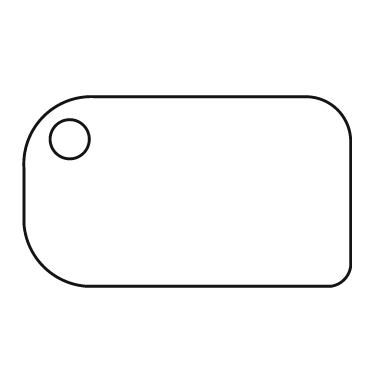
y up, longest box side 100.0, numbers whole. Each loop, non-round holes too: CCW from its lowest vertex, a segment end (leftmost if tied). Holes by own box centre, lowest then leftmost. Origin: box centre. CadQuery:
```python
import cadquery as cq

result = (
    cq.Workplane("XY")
    .moveTo(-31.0, -29.0)
    .lineTo(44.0, -29.0)
    .threePointArc((48.0, -27.0), (50.0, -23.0))
    .lineTo(50.0, 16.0)
    .threePointArc((46.0, 25.0), (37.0, 29.0))
    .lineTo(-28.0, 29.0)
    .threePointArc((-44.0, 23.0), (-50.0, 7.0))
    .lineTo(-50.0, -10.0)
    .threePointArc((-44.0, -23.0), (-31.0, -29.0))
    .close()
    .moveTo(-36.0, 16.0)
    .circle(6.0)
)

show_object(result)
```